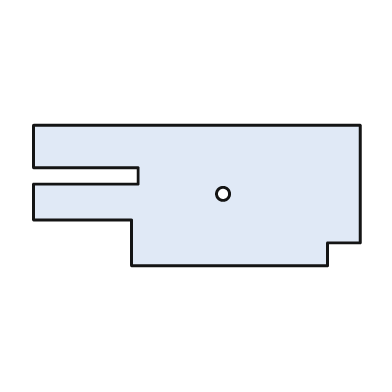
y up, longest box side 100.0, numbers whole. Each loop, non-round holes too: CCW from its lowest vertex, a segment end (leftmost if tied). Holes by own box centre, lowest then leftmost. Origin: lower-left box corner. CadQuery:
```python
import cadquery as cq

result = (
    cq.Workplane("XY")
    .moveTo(30.0, 0.0)
    .lineTo(90.0, 0.0)
    .lineTo(90.0, 7.0)
    .lineTo(100.0, 7.0)
    .lineTo(100.0, 43.0)
    .lineTo(0.0, 43.0)
    .lineTo(0.0, 30.0)
    .lineTo(32.0, 30.0)
    .lineTo(32.0, 25.0)
    .lineTo(0.0, 25.0)
    .lineTo(0.0, 14.0)
    .lineTo(30.0, 14.0)
    .close()
    .moveTo(58.0, 22.0)
    .circle(2.0)
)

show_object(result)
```